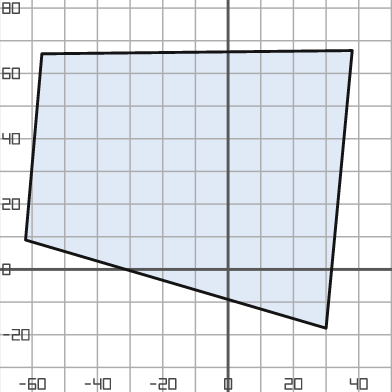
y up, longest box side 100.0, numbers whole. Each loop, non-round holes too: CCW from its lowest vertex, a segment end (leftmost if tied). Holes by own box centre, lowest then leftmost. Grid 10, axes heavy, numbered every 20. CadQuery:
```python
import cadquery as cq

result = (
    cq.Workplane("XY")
    .moveTo(30.0, -18.0)
    .lineTo(38.0, 67.0)
    .lineTo(-57.0, 66.0)
    .lineTo(-62.0, 9.0)
    .close()
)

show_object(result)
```